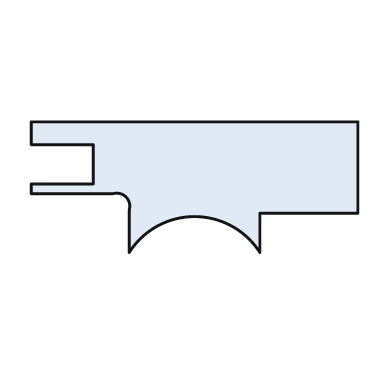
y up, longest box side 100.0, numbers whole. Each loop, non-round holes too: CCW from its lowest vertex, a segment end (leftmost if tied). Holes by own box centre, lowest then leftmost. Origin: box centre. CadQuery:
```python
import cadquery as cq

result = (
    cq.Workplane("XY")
    .moveTo(-20.0, -20.0)
    .threePointArc((0.0, -9.0), (20.0, -20.0))
    .lineTo(20.0, -8.0)
    .lineTo(50.0, -8.0)
    .lineTo(50.0, 20.0)
    .lineTo(-50.0, 20.0)
    .lineTo(-50.0, 13.0)
    .lineTo(-31.0, 13.0)
    .lineTo(-31.0, 1.0)
    .lineTo(-50.0, 1.0)
    .lineTo(-50.0, -2.0)
    .lineTo(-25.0, -2.0)
    .threePointArc((-21.0, -3.0), (-20.0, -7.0))
    .close()
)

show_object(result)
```